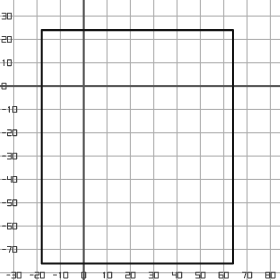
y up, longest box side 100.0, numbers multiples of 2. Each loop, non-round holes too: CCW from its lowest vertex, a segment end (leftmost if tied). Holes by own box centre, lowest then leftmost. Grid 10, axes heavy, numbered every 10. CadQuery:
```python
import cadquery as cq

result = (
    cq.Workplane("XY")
    .moveTo(-18.0, -76.0)
    .lineTo(64.0, -76.0)
    .lineTo(64.0, 24.0)
    .lineTo(-18.0, 24.0)
    .close()
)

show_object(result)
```